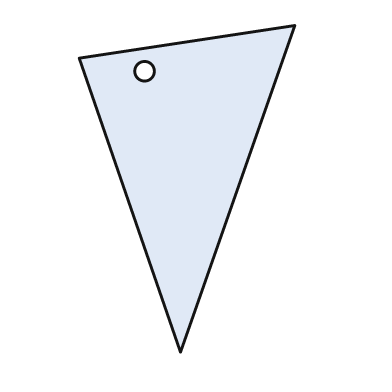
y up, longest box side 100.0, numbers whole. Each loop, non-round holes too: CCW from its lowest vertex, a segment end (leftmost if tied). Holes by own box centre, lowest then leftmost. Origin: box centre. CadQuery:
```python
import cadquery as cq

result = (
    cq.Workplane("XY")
    .moveTo(-2.0, -50.0)
    .lineTo(33.0, 50.0)
    .lineTo(-33.0, 40.0)
    .close()
    .moveTo(-13.0, 36.0)
    .circle(3.0)
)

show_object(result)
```